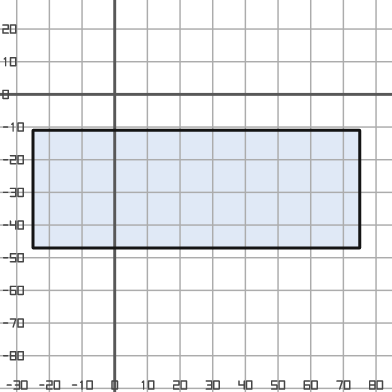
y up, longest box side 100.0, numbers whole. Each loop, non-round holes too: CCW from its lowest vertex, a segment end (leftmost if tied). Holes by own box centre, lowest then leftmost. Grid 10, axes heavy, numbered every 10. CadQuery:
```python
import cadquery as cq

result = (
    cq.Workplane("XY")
    .moveTo(-25.0, -47.0)
    .lineTo(75.0, -47.0)
    .lineTo(75.0, -11.0)
    .lineTo(-25.0, -11.0)
    .close()
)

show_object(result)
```